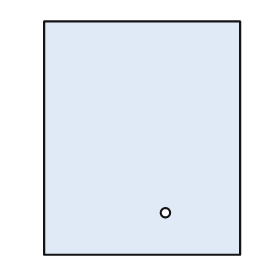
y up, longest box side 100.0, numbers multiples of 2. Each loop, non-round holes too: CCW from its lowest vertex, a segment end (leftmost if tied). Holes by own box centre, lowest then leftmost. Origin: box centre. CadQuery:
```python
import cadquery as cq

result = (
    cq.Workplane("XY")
    .moveTo(-42.0, -50.0)
    .lineTo(42.0, -50.0)
    .lineTo(42.0, 50.0)
    .lineTo(-42.0, 50.0)
    .close()
    .moveTo(10.0, -32.0)
    .circle(2.0)
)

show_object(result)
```